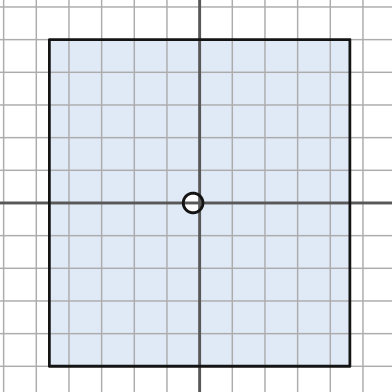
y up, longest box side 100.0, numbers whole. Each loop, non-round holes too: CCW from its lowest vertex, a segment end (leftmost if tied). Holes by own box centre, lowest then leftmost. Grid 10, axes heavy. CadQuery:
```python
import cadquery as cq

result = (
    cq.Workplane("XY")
    .moveTo(-46.0, -50.0)
    .lineTo(46.0, -50.0)
    .lineTo(46.0, 50.0)
    .lineTo(-46.0, 50.0)
    .close()
    .moveTo(-2.0, 0.0)
    .circle(3.0)
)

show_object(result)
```